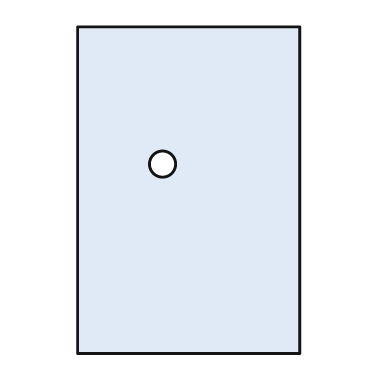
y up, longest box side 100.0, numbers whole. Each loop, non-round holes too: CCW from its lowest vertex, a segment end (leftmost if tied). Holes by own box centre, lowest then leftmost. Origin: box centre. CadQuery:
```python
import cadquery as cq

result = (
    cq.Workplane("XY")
    .moveTo(-34.0, -50.0)
    .lineTo(34.0, -50.0)
    .lineTo(34.0, 50.0)
    .lineTo(-34.0, 50.0)
    .close()
    .moveTo(-8.0, 8.0)
    .circle(4.0)
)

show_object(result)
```